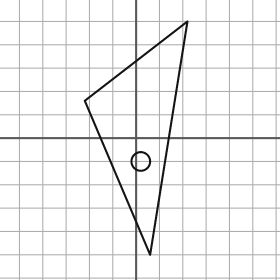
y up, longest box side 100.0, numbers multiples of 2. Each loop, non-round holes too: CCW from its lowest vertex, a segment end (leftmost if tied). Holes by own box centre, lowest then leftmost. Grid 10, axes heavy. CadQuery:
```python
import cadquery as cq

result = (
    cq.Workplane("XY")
    .moveTo(6.0, -50.0)
    .lineTo(22.0, 50.0)
    .lineTo(-22.0, 16.0)
    .close()
    .moveTo(2.0, -10.0)
    .circle(4.0)
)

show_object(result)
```